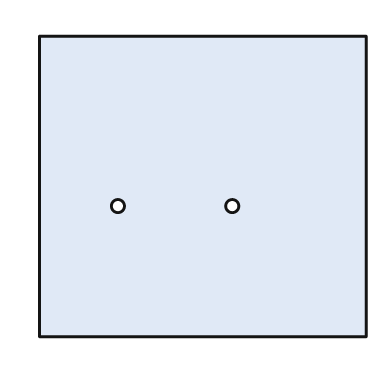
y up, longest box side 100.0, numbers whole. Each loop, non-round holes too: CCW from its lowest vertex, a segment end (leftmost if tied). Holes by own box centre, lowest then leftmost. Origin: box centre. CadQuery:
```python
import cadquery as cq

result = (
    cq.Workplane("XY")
    .moveTo(-50.0, -46.0)
    .lineTo(50.0, -46.0)
    .lineTo(50.0, 46.0)
    .lineTo(-50.0, 46.0)
    .close()
    .moveTo(-26.0, -6.0)
    .circle(2.0)
    .moveTo(9.0, -6.0)
    .circle(2.0)
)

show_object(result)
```